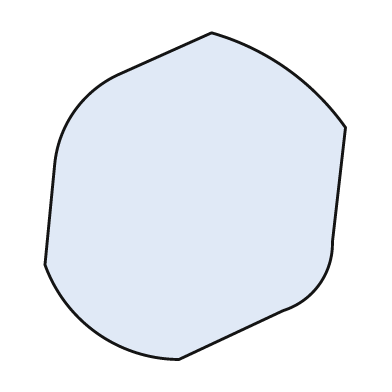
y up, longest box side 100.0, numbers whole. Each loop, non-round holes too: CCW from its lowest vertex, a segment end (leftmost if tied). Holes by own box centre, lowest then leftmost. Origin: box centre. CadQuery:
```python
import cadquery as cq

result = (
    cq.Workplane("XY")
    .moveTo(-5.0, -50.0)
    .lineTo(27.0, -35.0)
    .threePointArc((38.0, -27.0), (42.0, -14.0))
    .lineTo(46.0, 21.0)
    .threePointArc((28.0, 39.0), (5.0, 50.0))
    .lineTo(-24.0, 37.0)
    .threePointArc((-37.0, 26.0), (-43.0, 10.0))
    .lineTo(-46.0, -21.0)
    .threePointArc((-30.0, -42.0), (-5.0, -50.0))
    .close()
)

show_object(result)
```